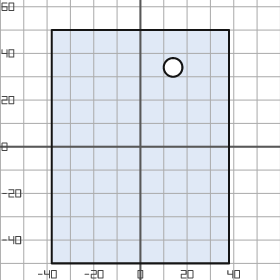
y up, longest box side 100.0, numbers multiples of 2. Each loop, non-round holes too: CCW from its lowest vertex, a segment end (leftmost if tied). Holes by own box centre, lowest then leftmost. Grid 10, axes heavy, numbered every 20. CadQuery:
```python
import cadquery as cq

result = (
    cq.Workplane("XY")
    .moveTo(-38.0, -50.0)
    .lineTo(38.0, -50.0)
    .lineTo(38.0, 50.0)
    .lineTo(-38.0, 50.0)
    .close()
    .moveTo(14.0, 34.0)
    .circle(4.0)
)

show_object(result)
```